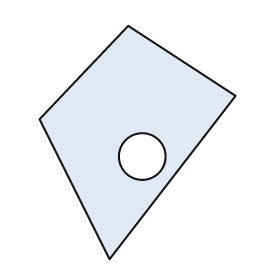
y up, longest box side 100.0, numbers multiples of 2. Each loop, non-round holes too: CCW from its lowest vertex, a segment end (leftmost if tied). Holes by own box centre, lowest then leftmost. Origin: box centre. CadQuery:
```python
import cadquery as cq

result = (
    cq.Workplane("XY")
    .moveTo(-12.0, -50.0)
    .lineTo(42.0, 20.0)
    .lineTo(-4.0, 50.0)
    .lineTo(-42.0, 10.0)
    .close()
    .moveTo(2.0, -6.0)
    .circle(10.0)
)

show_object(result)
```